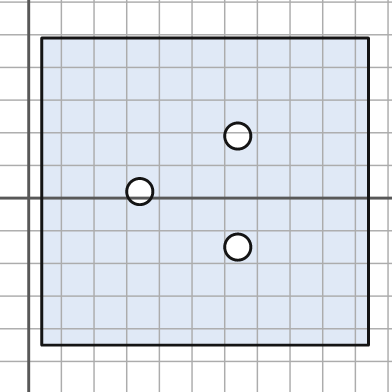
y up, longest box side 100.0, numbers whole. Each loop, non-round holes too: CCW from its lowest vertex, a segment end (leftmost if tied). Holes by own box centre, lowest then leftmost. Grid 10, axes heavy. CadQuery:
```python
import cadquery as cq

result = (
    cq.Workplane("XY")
    .moveTo(4.0, -45.0)
    .lineTo(104.0, -45.0)
    .lineTo(104.0, 49.0)
    .lineTo(4.0, 49.0)
    .close()
    .moveTo(64.0, -15.0)
    .circle(4.0)
    .moveTo(34.0, 2.0)
    .circle(4.0)
    .moveTo(64.0, 19.0)
    .circle(4.0)
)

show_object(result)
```